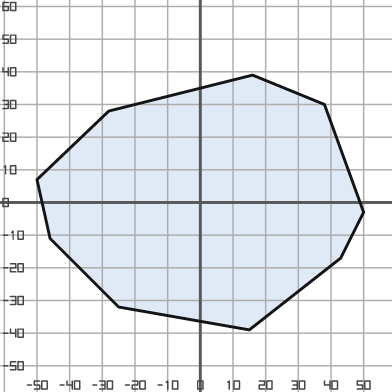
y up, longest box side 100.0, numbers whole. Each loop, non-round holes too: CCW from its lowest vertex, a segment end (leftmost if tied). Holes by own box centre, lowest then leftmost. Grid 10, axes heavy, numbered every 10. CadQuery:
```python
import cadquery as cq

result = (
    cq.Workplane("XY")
    .moveTo(15.0, -39.0)
    .lineTo(43.0, -17.0)
    .lineTo(50.0, -3.0)
    .lineTo(38.0, 30.0)
    .lineTo(16.0, 39.0)
    .lineTo(-28.0, 28.0)
    .lineTo(-50.0, 7.0)
    .lineTo(-46.0, -11.0)
    .lineTo(-25.0, -32.0)
    .close()
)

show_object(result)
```